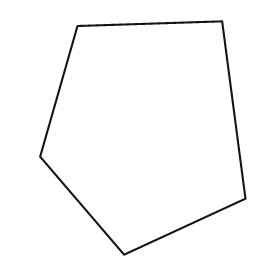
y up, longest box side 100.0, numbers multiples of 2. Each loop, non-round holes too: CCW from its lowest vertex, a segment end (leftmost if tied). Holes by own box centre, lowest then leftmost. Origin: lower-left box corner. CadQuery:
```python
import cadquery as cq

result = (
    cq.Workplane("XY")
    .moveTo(36.0, 0.0)
    .lineTo(88.0, 24.0)
    .lineTo(78.0, 100.0)
    .lineTo(16.0, 98.0)
    .lineTo(0.0, 42.0)
    .close()
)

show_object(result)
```